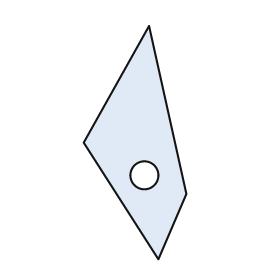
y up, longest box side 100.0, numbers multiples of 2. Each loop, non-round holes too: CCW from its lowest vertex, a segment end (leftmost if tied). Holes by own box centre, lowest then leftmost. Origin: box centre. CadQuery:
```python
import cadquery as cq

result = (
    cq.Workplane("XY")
    .moveTo(10.0, -50.0)
    .lineTo(22.0, -22.0)
    .lineTo(6.0, 50.0)
    .lineTo(-22.0, 0.0)
    .close()
    .moveTo(4.0, -14.0)
    .circle(6.0)
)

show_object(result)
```